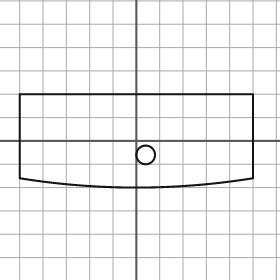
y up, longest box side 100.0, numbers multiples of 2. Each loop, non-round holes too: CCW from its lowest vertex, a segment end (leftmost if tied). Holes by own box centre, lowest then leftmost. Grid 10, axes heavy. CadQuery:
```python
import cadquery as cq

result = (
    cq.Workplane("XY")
    .moveTo(-50.0, -16.0)
    .threePointArc((0.0, -20.0), (50.0, -16.0))
    .lineTo(50.0, 20.0)
    .lineTo(-50.0, 20.0)
    .close()
    .moveTo(4.0, -6.0)
    .circle(4.0)
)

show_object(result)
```